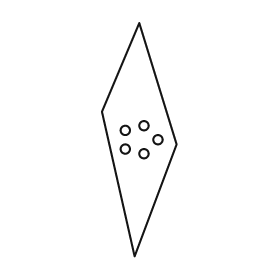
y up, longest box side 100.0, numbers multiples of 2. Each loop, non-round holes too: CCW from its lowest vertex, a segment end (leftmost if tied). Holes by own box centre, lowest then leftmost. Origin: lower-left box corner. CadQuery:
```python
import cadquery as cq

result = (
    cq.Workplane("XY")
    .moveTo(14.0, 0.0)
    .lineTo(32.0, 48.0)
    .lineTo(16.0, 100.0)
    .lineTo(0.0, 62.0)
    .close()
    .moveTo(18.0, 44.0)
    .circle(2.0)
    .moveTo(10.0, 46.0)
    .circle(2.0)
    .moveTo(24.0, 50.0)
    .circle(2.0)
    .moveTo(10.0, 54.0)
    .circle(2.0)
    .moveTo(18.0, 56.0)
    .circle(2.0)
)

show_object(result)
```